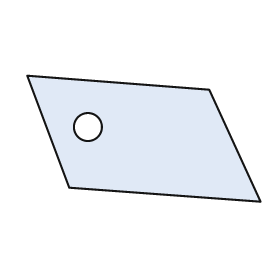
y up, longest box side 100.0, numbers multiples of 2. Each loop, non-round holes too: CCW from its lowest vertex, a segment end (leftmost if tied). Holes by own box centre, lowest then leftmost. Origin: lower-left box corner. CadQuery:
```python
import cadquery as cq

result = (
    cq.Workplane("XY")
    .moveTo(100.0, 0.0)
    .lineTo(78.0, 48.0)
    .lineTo(0.0, 54.0)
    .lineTo(18.0, 6.0)
    .close()
    .moveTo(26.0, 32.0)
    .circle(6.0)
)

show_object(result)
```